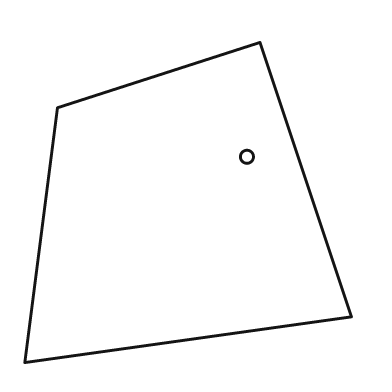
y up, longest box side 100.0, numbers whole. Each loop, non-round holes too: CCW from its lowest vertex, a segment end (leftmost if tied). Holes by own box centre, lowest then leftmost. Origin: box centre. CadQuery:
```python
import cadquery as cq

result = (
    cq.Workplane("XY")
    .moveTo(-50.0, -49.0)
    .lineTo(50.0, -35.0)
    .lineTo(22.0, 49.0)
    .lineTo(-40.0, 29.0)
    .close()
    .moveTo(18.0, 14.0)
    .circle(2.0)
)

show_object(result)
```